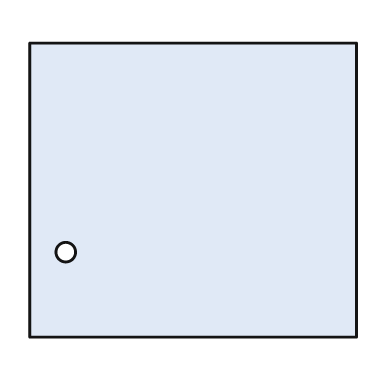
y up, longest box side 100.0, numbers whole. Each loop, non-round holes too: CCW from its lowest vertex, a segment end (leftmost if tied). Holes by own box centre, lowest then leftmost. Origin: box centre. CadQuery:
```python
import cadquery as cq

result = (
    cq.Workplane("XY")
    .moveTo(-50.0, -45.0)
    .lineTo(50.0, -45.0)
    .lineTo(50.0, 45.0)
    .lineTo(-50.0, 45.0)
    .close()
    .moveTo(-39.0, -19.0)
    .circle(3.0)
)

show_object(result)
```